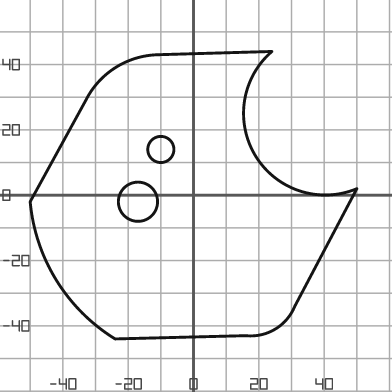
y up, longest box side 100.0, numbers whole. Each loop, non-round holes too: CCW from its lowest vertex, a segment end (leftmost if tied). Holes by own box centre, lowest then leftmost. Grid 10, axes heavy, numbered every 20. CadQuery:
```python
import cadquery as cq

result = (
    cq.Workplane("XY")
    .moveTo(-24.0, -44.0)
    .lineTo(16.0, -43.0)
    .threePointArc((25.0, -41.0), (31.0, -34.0))
    .lineTo(50.0, 2.0)
    .threePointArc((19.0, 12.0), (24.0, 44.0))
    .lineTo(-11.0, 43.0)
    .threePointArc((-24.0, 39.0), (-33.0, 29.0))
    .lineTo(-50.0, -2.0)
    .threePointArc((-42.0, -26.0), (-24.0, -44.0))
    .close()
    .moveTo(-17.0, -2.0)
    .circle(6.0)
    .moveTo(-10.0, 14.0)
    .circle(4.0)
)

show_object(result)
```